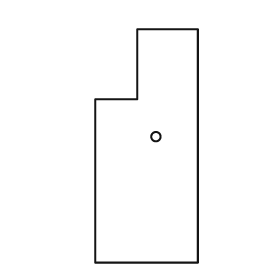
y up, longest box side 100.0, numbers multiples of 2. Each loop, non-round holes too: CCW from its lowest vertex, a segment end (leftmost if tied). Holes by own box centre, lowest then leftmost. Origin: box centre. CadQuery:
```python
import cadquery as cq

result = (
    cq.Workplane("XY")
    .moveTo(-22.0, -50.0)
    .lineTo(22.0, -50.0)
    .lineTo(22.0, 50.0)
    .lineTo(-4.0, 50.0)
    .lineTo(-4.0, 20.0)
    .lineTo(-22.0, 20.0)
    .close()
    .moveTo(4.0, 4.0)
    .circle(2.0)
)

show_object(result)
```